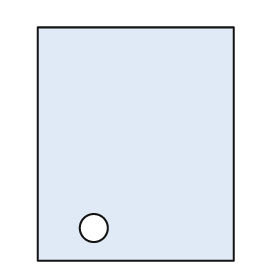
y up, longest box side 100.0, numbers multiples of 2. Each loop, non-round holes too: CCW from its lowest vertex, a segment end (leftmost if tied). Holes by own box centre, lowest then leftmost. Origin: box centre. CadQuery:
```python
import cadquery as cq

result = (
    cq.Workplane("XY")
    .moveTo(-42.0, -50.0)
    .lineTo(42.0, -50.0)
    .lineTo(42.0, 50.0)
    .lineTo(-42.0, 50.0)
    .close()
    .moveTo(-18.0, -36.0)
    .circle(6.0)
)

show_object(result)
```